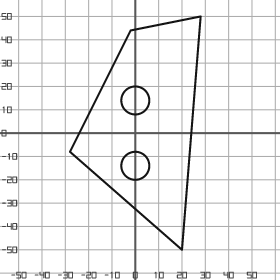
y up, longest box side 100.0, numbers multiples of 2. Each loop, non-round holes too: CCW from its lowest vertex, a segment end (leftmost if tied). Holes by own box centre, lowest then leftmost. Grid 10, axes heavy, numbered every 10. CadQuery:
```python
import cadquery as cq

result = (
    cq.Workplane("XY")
    .moveTo(20.0, -50.0)
    .lineTo(28.0, 50.0)
    .lineTo(-2.0, 44.0)
    .lineTo(-28.0, -8.0)
    .close()
    .moveTo(0.0, -14.0)
    .circle(6.0)
    .moveTo(0.0, 14.0)
    .circle(6.0)
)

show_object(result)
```